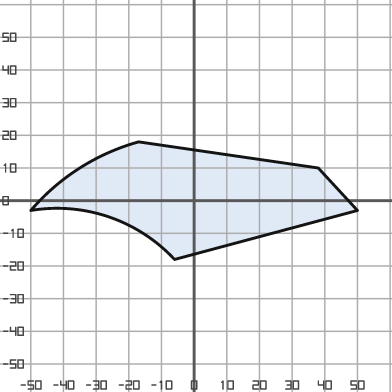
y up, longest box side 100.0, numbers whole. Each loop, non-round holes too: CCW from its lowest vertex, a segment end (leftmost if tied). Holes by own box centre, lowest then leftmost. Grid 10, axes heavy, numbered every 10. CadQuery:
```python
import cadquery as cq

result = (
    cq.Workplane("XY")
    .moveTo(-6.0, -18.0)
    .lineTo(50.0, -3.0)
    .lineTo(38.0, 10.0)
    .lineTo(-17.0, 18.0)
    .threePointArc((-35.0, 10.0), (-50.0, -3.0))
    .threePointArc((-26.0, -5.0), (-6.0, -18.0))
    .close()
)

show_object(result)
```